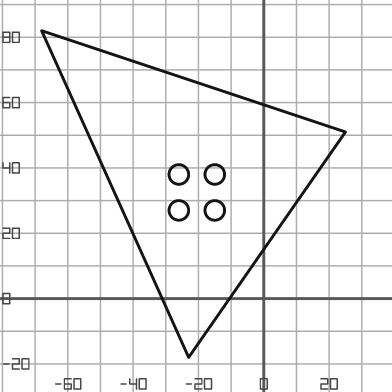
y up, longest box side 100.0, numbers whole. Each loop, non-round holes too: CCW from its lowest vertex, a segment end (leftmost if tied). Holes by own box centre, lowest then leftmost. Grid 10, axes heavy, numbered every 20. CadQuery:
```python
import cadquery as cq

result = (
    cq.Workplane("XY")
    .moveTo(-23.0, -18.0)
    .lineTo(25.0, 51.0)
    .lineTo(-68.0, 82.0)
    .close()
    .moveTo(-26.0, 27.0)
    .circle(3.0)
    .moveTo(-15.0, 27.0)
    .circle(3.0)
    .moveTo(-26.0, 38.0)
    .circle(3.0)
    .moveTo(-15.0, 38.0)
    .circle(3.0)
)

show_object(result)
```